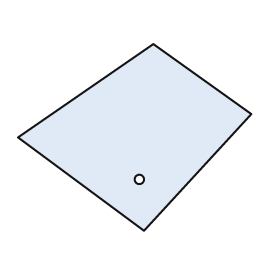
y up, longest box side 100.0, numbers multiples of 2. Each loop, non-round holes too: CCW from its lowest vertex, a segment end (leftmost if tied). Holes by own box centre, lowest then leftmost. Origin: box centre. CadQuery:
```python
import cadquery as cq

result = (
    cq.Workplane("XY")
    .moveTo(4.0, -40.0)
    .lineTo(50.0, 10.0)
    .lineTo(8.0, 40.0)
    .lineTo(-50.0, 0.0)
    .close()
    .moveTo(2.0, -18.0)
    .circle(2.0)
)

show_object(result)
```